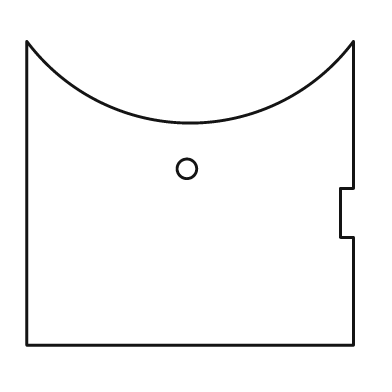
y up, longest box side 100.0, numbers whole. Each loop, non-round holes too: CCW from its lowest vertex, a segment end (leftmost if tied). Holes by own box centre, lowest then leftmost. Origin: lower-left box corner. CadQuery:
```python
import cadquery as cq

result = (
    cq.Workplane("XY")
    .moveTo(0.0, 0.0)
    .lineTo(100.0, 0.0)
    .lineTo(100.0, 33.0)
    .lineTo(96.0, 33.0)
    .lineTo(96.0, 48.0)
    .lineTo(100.0, 48.0)
    .lineTo(100.0, 93.0)
    .threePointArc((50.0, 68.0), (0.0, 93.0))
    .close()
    .moveTo(49.0, 54.0)
    .circle(3.0)
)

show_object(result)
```